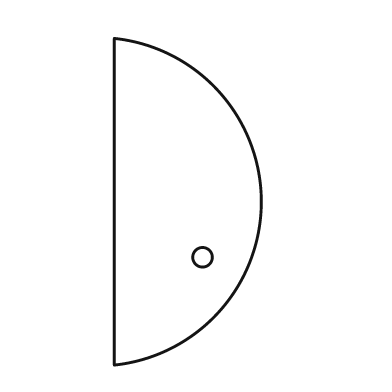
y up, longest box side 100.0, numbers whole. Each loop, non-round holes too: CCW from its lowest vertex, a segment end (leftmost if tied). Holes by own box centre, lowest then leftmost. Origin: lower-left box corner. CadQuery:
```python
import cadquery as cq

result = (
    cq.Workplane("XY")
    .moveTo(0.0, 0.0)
    .threePointArc((45.0, 50.0), (0.0, 100.0))
    .close()
    .moveTo(27.0, 33.0)
    .circle(3.0)
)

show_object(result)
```